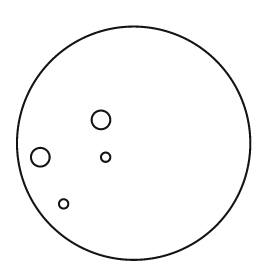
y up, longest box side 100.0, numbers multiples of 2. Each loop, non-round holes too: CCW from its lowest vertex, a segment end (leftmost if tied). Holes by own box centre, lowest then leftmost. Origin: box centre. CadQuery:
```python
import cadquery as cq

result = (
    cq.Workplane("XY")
    .moveTo(0.0, 0.0)
    .circle(50.0)
    .moveTo(-30.0, -26.0)
    .circle(2.0)
    .moveTo(-40.0, -6.0)
    .circle(4.0)
    .moveTo(-12.0, -6.0)
    .circle(2.0)
    .moveTo(-14.0, 10.0)
    .circle(4.0)
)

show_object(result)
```